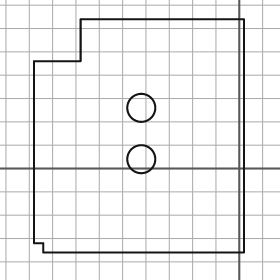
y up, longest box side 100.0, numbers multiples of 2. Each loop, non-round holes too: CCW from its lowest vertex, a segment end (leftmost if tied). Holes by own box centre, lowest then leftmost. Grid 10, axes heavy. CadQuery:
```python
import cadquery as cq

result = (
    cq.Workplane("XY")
    .moveTo(-84.0, -36.0)
    .lineTo(2.0, -36.0)
    .lineTo(2.0, 64.0)
    .lineTo(-68.0, 64.0)
    .lineTo(-68.0, 46.0)
    .lineTo(-88.0, 46.0)
    .lineTo(-88.0, -32.0)
    .lineTo(-84.0, -32.0)
    .close()
    .moveTo(-42.0, 4.0)
    .circle(6.0)
    .moveTo(-42.0, 26.0)
    .circle(6.0)
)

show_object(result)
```